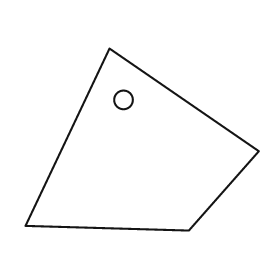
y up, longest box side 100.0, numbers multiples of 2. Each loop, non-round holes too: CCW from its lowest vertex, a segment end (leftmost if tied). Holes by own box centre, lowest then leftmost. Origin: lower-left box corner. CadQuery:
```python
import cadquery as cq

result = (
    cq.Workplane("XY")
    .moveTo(70.0, 0.0)
    .lineTo(100.0, 34.0)
    .lineTo(36.0, 78.0)
    .lineTo(0.0, 2.0)
    .close()
    .moveTo(42.0, 56.0)
    .circle(4.0)
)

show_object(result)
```